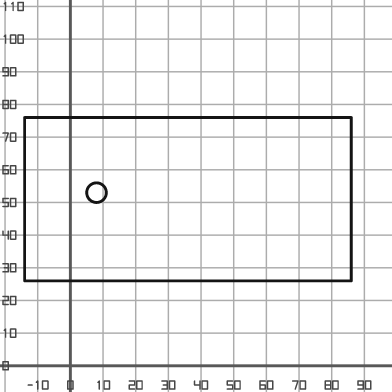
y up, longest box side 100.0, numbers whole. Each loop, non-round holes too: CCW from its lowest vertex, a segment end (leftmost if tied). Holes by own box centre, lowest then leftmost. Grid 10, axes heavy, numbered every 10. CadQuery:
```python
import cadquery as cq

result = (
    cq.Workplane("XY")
    .moveTo(-14.0, 26.0)
    .lineTo(86.0, 26.0)
    .lineTo(86.0, 76.0)
    .lineTo(-14.0, 76.0)
    .close()
    .moveTo(8.0, 53.0)
    .circle(3.0)
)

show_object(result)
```